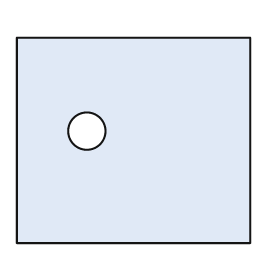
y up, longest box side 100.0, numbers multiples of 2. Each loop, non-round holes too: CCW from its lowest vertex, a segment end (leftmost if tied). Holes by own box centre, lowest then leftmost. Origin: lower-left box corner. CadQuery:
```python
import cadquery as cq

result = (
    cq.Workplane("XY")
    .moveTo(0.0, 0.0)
    .lineTo(100.0, 0.0)
    .lineTo(100.0, 88.0)
    .lineTo(0.0, 88.0)
    .close()
    .moveTo(30.0, 48.0)
    .circle(8.0)
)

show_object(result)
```